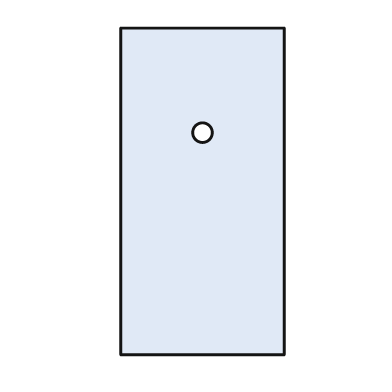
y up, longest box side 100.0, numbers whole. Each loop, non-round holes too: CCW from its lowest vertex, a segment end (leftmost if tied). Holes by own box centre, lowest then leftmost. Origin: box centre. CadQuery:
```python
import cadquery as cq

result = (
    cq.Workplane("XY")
    .moveTo(-25.0, -50.0)
    .lineTo(25.0, -50.0)
    .lineTo(25.0, 50.0)
    .lineTo(-25.0, 50.0)
    .close()
    .moveTo(0.0, 18.0)
    .circle(3.0)
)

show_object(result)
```